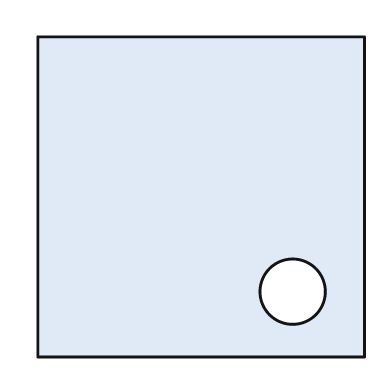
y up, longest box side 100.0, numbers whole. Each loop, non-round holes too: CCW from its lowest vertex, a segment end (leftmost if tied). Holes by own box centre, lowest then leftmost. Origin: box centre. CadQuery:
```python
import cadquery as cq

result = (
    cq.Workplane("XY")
    .moveTo(-50.0, -49.0)
    .lineTo(50.0, -49.0)
    .lineTo(50.0, 49.0)
    .lineTo(-50.0, 49.0)
    .close()
    .moveTo(28.0, -29.0)
    .circle(10.0)
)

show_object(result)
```